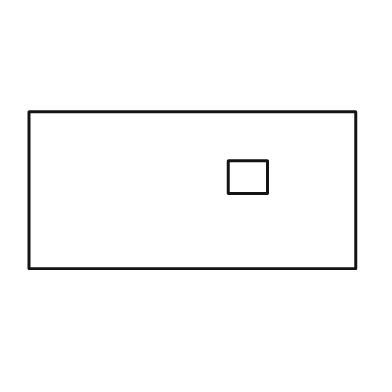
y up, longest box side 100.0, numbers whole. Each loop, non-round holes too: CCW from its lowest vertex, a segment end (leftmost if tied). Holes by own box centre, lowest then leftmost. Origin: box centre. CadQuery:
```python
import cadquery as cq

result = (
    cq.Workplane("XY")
    .moveTo(-50.0, -24.0)
    .lineTo(50.0, -24.0)
    .lineTo(50.0, 24.0)
    .lineTo(-50.0, 24.0)
    .close()
    .moveTo(11.0, -1.0)
    .lineTo(23.0, -1.0)
    .lineTo(23.0, 9.0)
    .lineTo(11.0, 9.0)
    .close()
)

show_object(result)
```